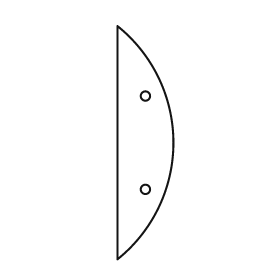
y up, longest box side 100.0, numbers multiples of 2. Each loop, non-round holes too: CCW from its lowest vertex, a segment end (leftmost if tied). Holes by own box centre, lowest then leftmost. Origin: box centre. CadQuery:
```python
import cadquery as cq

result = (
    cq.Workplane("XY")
    .moveTo(-12.0, -50.0)
    .threePointArc((12.0, 0.0), (-12.0, 50.0))
    .close()
    .moveTo(0.0, -20.0)
    .circle(2.0)
    .moveTo(0.0, 20.0)
    .circle(2.0)
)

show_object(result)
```